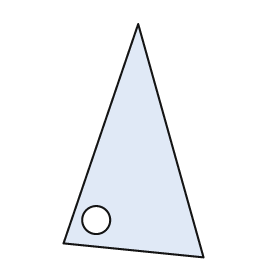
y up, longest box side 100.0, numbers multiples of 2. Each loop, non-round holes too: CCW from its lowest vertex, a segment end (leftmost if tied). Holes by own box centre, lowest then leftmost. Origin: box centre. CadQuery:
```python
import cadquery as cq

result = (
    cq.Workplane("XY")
    .moveTo(30.0, -50.0)
    .lineTo(2.0, 50.0)
    .lineTo(-30.0, -44.0)
    .close()
    .moveTo(-16.0, -34.0)
    .circle(6.0)
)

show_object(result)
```